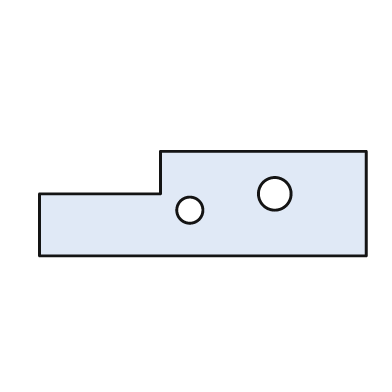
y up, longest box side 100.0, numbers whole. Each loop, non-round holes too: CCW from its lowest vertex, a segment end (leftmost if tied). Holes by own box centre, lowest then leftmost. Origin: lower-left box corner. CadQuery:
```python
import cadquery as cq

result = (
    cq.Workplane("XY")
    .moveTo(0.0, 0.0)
    .lineTo(100.0, 0.0)
    .lineTo(100.0, 32.0)
    .lineTo(37.0, 32.0)
    .lineTo(37.0, 19.0)
    .lineTo(0.0, 19.0)
    .close()
    .moveTo(46.0, 14.0)
    .circle(4.0)
    .moveTo(72.0, 19.0)
    .circle(5.0)
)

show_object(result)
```